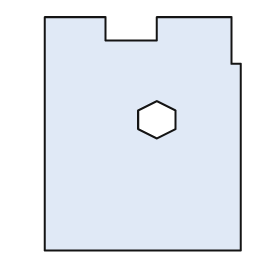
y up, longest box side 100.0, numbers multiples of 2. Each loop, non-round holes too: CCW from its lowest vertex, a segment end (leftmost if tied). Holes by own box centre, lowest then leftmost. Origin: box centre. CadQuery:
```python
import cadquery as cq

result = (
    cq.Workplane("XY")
    .moveTo(-42.0, -50.0)
    .lineTo(42.0, -50.0)
    .lineTo(42.0, 30.0)
    .lineTo(38.0, 30.0)
    .lineTo(38.0, 50.0)
    .lineTo(6.0, 50.0)
    .lineTo(6.0, 40.0)
    .lineTo(-16.0, 40.0)
    .lineTo(-16.0, 50.0)
    .lineTo(-42.0, 50.0)
    .close()
    .moveTo(6.0, -2.0)
    .lineTo(14.0, 2.0)
    .lineTo(14.0, 10.0)
    .lineTo(6.0, 14.0)
    .lineTo(-2.0, 10.0)
    .lineTo(-2.0, 2.0)
    .close()
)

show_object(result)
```